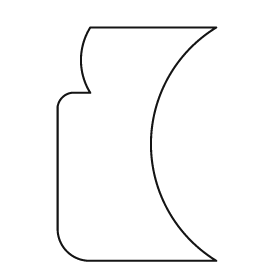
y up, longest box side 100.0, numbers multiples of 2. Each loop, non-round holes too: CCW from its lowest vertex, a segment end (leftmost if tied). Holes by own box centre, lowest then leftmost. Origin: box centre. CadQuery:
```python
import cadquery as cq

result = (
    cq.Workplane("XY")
    .moveTo(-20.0, -50.0)
    .lineTo(34.0, -50.0)
    .threePointArc((6.0, 0.0), (34.0, 50.0))
    .lineTo(-20.0, 50.0)
    .threePointArc((-24.0, 36.0), (-20.0, 22.0))
    .lineTo(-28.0, 22.0)
    .threePointArc((-32.0, 20.0), (-34.0, 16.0))
    .lineTo(-34.0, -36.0)
    .threePointArc((-30.0, -46.0), (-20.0, -50.0))
    .close()
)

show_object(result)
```